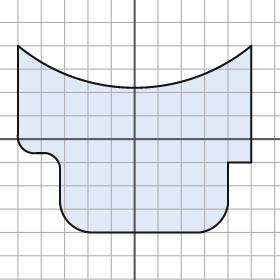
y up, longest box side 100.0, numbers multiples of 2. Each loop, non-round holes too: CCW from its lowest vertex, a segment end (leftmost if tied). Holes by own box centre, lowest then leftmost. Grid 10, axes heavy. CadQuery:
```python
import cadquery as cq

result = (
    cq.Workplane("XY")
    .moveTo(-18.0, -40.0)
    .lineTo(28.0, -40.0)
    .threePointArc((36.0, -36.0), (40.0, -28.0))
    .lineTo(40.0, -10.0)
    .lineTo(50.0, -10.0)
    .lineTo(50.0, 40.0)
    .threePointArc((0.0, 22.0), (-50.0, 40.0))
    .lineTo(-50.0, 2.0)
    .threePointArc((-48.0, -4.0), (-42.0, -6.0))
    .lineTo(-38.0, -6.0)
    .threePointArc((-34.0, -8.0), (-32.0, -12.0))
    .lineTo(-32.0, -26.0)
    .threePointArc((-28.0, -36.0), (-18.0, -40.0))
    .close()
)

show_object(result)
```